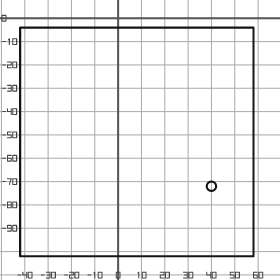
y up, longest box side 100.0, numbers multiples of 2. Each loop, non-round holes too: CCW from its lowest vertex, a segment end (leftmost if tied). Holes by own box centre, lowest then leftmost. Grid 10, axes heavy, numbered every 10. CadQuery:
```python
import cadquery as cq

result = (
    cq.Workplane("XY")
    .moveTo(-42.0, -102.0)
    .lineTo(58.0, -102.0)
    .lineTo(58.0, -4.0)
    .lineTo(-42.0, -4.0)
    .close()
    .moveTo(40.0, -72.0)
    .circle(2.0)
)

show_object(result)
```